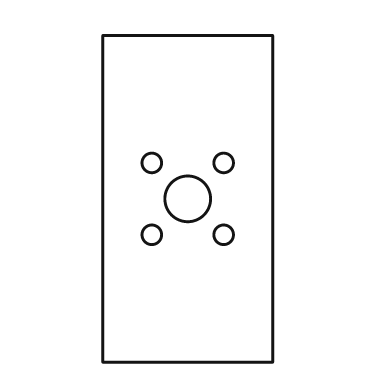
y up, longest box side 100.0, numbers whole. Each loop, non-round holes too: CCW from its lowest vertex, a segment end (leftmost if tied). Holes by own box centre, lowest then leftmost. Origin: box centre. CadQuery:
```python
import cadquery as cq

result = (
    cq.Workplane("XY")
    .moveTo(-26.0, -50.0)
    .lineTo(26.0, -50.0)
    .lineTo(26.0, 50.0)
    .lineTo(-26.0, 50.0)
    .close()
    .moveTo(-11.0, -11.0)
    .circle(3.0)
    .moveTo(11.0, -11.0)
    .circle(3.0)
    .moveTo(0.0, 0.0)
    .circle(7.0)
    .moveTo(-11.0, 11.0)
    .circle(3.0)
    .moveTo(11.0, 11.0)
    .circle(3.0)
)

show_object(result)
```